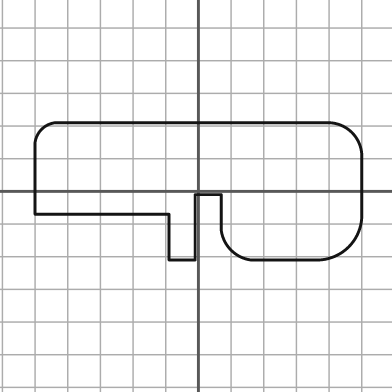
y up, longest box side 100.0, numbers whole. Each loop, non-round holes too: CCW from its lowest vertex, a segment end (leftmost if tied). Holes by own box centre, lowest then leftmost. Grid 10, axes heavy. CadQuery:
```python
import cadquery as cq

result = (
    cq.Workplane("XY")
    .moveTo(-9.0, -21.0)
    .lineTo(-1.0, -21.0)
    .lineTo(-1.0, -1.0)
    .lineTo(7.0, -1.0)
    .lineTo(7.0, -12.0)
    .threePointArc((10.0, -18.0), (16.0, -21.0))
    .lineTo(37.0, -21.0)
    .threePointArc((46.0, -17.0), (50.0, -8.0))
    .lineTo(50.0, 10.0)
    .threePointArc((47.0, 18.0), (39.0, 21.0))
    .lineTo(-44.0, 21.0)
    .threePointArc((-48.0, 19.0), (-50.0, 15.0))
    .lineTo(-50.0, -7.0)
    .lineTo(-9.0, -7.0)
    .close()
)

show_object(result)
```